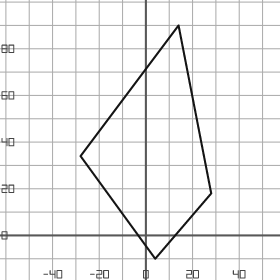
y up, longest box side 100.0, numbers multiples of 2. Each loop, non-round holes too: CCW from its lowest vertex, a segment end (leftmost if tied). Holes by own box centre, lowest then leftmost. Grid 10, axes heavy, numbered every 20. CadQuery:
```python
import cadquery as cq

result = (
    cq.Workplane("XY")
    .moveTo(4.0, -10.0)
    .lineTo(28.0, 18.0)
    .lineTo(14.0, 90.0)
    .lineTo(-28.0, 34.0)
    .close()
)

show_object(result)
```